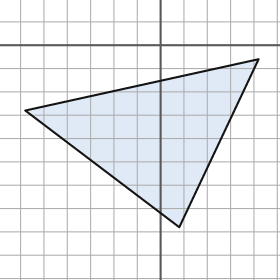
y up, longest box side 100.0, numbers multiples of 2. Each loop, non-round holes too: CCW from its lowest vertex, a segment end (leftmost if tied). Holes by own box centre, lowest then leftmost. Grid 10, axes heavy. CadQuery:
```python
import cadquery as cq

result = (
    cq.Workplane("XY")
    .moveTo(8.0, -78.0)
    .lineTo(42.0, -6.0)
    .lineTo(-58.0, -28.0)
    .close()
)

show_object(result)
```